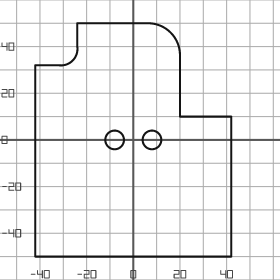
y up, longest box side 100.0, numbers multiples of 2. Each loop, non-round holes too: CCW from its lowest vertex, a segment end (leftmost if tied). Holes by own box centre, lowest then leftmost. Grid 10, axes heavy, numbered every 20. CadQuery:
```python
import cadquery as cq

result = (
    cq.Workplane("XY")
    .moveTo(-42.0, -50.0)
    .lineTo(42.0, -50.0)
    .lineTo(42.0, 10.0)
    .lineTo(20.0, 10.0)
    .lineTo(20.0, 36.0)
    .threePointArc((16.0, 46.0), (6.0, 50.0))
    .lineTo(-24.0, 50.0)
    .lineTo(-24.0, 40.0)
    .threePointArc((-26.0, 34.0), (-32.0, 32.0))
    .lineTo(-42.0, 32.0)
    .close()
    .moveTo(-8.0, 0.0)
    .circle(4.0)
    .moveTo(8.0, 0.0)
    .circle(4.0)
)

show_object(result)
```